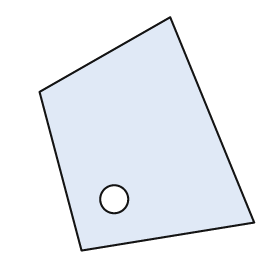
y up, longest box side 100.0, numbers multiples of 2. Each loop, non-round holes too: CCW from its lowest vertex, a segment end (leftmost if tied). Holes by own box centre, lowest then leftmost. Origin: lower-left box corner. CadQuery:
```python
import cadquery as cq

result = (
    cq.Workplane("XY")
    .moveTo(18.0, 0.0)
    .lineTo(92.0, 12.0)
    .lineTo(56.0, 100.0)
    .lineTo(0.0, 68.0)
    .close()
    .moveTo(32.0, 22.0)
    .circle(6.0)
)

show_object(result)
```